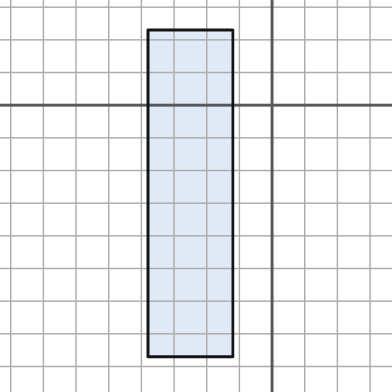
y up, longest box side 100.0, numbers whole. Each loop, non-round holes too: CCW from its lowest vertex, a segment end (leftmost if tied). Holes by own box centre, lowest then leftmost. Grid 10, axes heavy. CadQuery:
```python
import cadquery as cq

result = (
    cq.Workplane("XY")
    .moveTo(-38.0, -77.0)
    .lineTo(-12.0, -77.0)
    .lineTo(-12.0, 23.0)
    .lineTo(-38.0, 23.0)
    .close()
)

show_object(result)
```